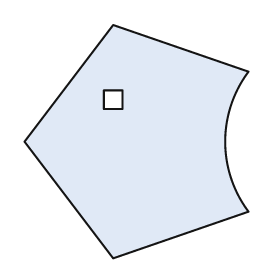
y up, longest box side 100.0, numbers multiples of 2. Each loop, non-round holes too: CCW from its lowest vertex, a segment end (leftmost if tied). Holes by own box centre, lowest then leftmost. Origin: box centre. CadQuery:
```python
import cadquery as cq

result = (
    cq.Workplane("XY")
    .moveTo(-10.0, -50.0)
    .lineTo(48.0, -30.0)
    .threePointArc((38.0, 0.0), (48.0, 30.0))
    .lineTo(-10.0, 50.0)
    .lineTo(-48.0, 0.0)
    .close()
    .moveTo(-14.0, 14.0)
    .lineTo(-6.0, 14.0)
    .lineTo(-6.0, 22.0)
    .lineTo(-14.0, 22.0)
    .close()
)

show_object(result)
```